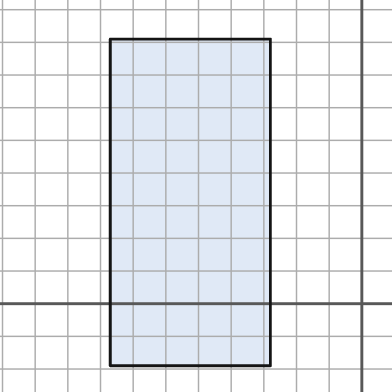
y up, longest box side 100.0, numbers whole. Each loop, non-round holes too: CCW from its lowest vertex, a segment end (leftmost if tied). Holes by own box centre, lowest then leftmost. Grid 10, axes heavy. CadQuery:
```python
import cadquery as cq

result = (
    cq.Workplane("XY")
    .moveTo(-77.0, -19.0)
    .lineTo(-28.0, -19.0)
    .lineTo(-28.0, 81.0)
    .lineTo(-77.0, 81.0)
    .close()
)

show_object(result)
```